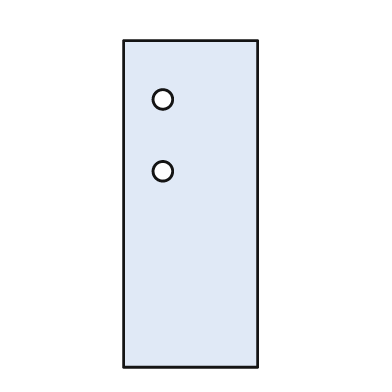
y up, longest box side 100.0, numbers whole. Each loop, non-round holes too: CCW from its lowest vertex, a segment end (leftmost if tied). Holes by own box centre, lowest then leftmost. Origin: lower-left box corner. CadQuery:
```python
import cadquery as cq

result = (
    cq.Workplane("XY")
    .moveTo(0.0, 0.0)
    .lineTo(41.0, 0.0)
    .lineTo(41.0, 100.0)
    .lineTo(0.0, 100.0)
    .close()
    .moveTo(12.0, 60.0)
    .circle(3.0)
    .moveTo(12.0, 82.0)
    .circle(3.0)
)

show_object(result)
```